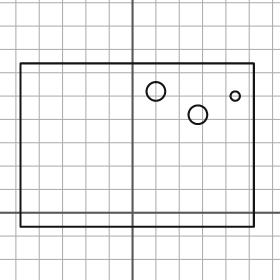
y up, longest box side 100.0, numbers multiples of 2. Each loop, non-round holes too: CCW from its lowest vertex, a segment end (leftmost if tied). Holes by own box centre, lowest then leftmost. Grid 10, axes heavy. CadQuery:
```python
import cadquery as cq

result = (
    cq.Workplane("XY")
    .moveTo(-48.0, -6.0)
    .lineTo(52.0, -6.0)
    .lineTo(52.0, 64.0)
    .lineTo(-48.0, 64.0)
    .close()
    .moveTo(28.0, 42.0)
    .circle(4.0)
    .moveTo(44.0, 50.0)
    .circle(2.0)
    .moveTo(10.0, 52.0)
    .circle(4.0)
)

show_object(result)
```